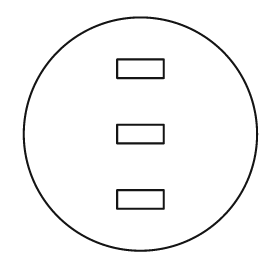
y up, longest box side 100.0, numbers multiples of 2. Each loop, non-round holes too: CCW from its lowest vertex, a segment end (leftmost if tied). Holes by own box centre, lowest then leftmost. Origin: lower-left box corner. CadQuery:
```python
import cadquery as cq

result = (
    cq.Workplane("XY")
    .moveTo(50.0, 50.0)
    .circle(50.0)
    .moveTo(40.0, 18.0)
    .lineTo(60.0, 18.0)
    .lineTo(60.0, 26.0)
    .lineTo(40.0, 26.0)
    .close()
    .moveTo(40.0, 46.0)
    .lineTo(60.0, 46.0)
    .lineTo(60.0, 54.0)
    .lineTo(40.0, 54.0)
    .close()
    .moveTo(40.0, 74.0)
    .lineTo(60.0, 74.0)
    .lineTo(60.0, 82.0)
    .lineTo(40.0, 82.0)
    .close()
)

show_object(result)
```